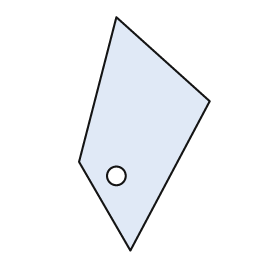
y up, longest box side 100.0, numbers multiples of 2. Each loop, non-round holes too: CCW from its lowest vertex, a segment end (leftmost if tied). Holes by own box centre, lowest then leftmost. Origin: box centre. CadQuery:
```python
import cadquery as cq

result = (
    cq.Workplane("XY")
    .moveTo(-6.0, -50.0)
    .lineTo(28.0, 14.0)
    .lineTo(-12.0, 50.0)
    .lineTo(-28.0, -12.0)
    .close()
    .moveTo(-12.0, -18.0)
    .circle(4.0)
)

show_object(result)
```